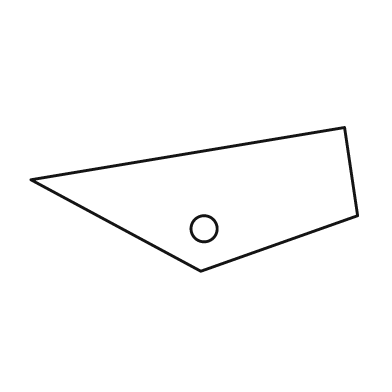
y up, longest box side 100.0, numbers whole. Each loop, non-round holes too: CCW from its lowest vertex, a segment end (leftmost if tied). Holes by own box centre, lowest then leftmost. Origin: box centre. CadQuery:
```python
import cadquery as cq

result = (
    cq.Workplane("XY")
    .moveTo(2.0, -22.0)
    .lineTo(50.0, -5.0)
    .lineTo(46.0, 22.0)
    .lineTo(-50.0, 6.0)
    .close()
    .moveTo(3.0, -9.0)
    .circle(4.0)
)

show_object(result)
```